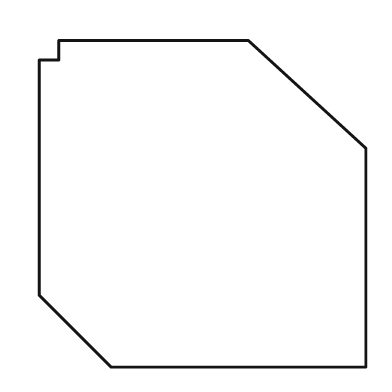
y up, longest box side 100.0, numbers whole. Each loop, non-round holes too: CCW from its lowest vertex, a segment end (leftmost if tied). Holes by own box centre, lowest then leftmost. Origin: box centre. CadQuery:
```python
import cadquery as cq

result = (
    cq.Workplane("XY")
    .moveTo(-28.0, -50.0)
    .lineTo(50.0, -50.0)
    .lineTo(50.0, 17.0)
    .lineTo(14.0, 50.0)
    .lineTo(-44.0, 50.0)
    .lineTo(-44.0, 44.0)
    .lineTo(-50.0, 44.0)
    .lineTo(-50.0, -28.0)
    .close()
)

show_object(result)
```